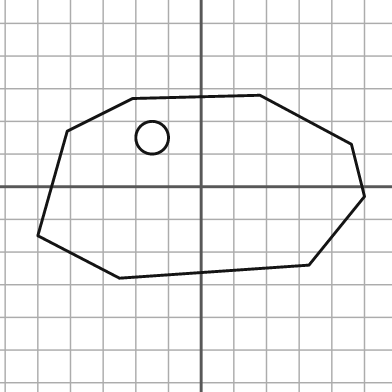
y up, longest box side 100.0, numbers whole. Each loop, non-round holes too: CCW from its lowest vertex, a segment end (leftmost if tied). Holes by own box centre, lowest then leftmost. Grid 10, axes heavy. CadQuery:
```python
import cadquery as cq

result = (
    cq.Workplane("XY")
    .moveTo(-25.0, -28.0)
    .lineTo(33.0, -24.0)
    .lineTo(50.0, -3.0)
    .lineTo(46.0, 13.0)
    .lineTo(18.0, 28.0)
    .lineTo(-21.0, 27.0)
    .lineTo(-41.0, 17.0)
    .lineTo(-50.0, -15.0)
    .close()
    .moveTo(-15.0, 15.0)
    .circle(5.0)
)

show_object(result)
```